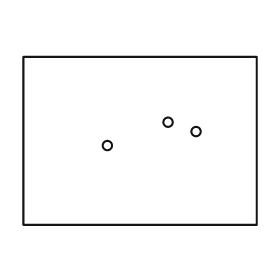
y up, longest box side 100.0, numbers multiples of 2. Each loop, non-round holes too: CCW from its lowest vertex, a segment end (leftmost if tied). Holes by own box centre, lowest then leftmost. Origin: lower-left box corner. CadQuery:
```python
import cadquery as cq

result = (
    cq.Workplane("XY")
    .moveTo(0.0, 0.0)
    .lineTo(100.0, 0.0)
    .lineTo(100.0, 72.0)
    .lineTo(0.0, 72.0)
    .close()
    .moveTo(36.0, 34.0)
    .circle(2.0)
    .moveTo(74.0, 40.0)
    .circle(2.0)
    .moveTo(62.0, 44.0)
    .circle(2.0)
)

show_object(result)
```